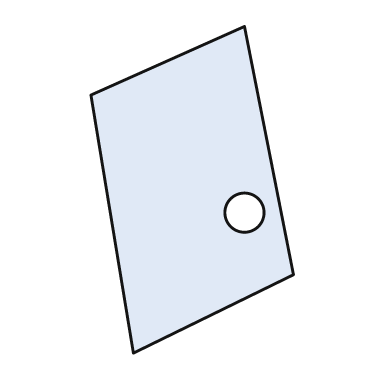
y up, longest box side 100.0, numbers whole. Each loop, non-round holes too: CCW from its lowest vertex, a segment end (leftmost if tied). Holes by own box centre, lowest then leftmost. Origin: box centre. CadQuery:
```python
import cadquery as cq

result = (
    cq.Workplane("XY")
    .moveTo(-18.0, -50.0)
    .lineTo(31.0, -26.0)
    .lineTo(16.0, 50.0)
    .lineTo(-31.0, 29.0)
    .close()
    .moveTo(16.0, -7.0)
    .circle(6.0)
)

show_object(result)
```